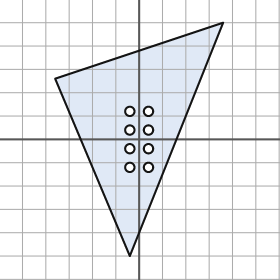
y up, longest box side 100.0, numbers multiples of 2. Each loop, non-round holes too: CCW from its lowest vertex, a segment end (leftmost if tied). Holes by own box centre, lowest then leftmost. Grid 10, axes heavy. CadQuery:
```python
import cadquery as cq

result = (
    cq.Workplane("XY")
    .moveTo(-4.0, -50.0)
    .lineTo(36.0, 50.0)
    .lineTo(-36.0, 26.0)
    .close()
    .moveTo(-4.0, -12.0)
    .circle(2.0)
    .moveTo(4.0, -12.0)
    .circle(2.0)
    .moveTo(-4.0, -4.0)
    .circle(2.0)
    .moveTo(4.0, -4.0)
    .circle(2.0)
    .moveTo(-4.0, 4.0)
    .circle(2.0)
    .moveTo(4.0, 4.0)
    .circle(2.0)
    .moveTo(-4.0, 12.0)
    .circle(2.0)
    .moveTo(4.0, 12.0)
    .circle(2.0)
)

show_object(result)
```